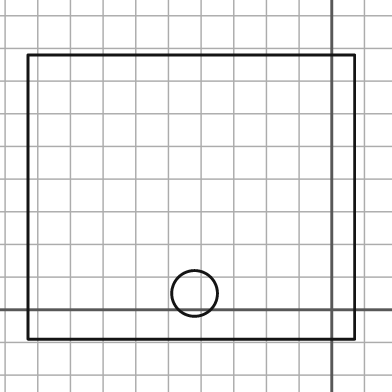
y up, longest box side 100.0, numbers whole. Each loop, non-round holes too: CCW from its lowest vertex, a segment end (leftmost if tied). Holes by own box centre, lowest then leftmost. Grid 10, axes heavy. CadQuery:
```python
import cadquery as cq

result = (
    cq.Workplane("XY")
    .moveTo(-93.0, -9.0)
    .lineTo(7.0, -9.0)
    .lineTo(7.0, 78.0)
    .lineTo(-93.0, 78.0)
    .close()
    .moveTo(-42.0, 5.0)
    .circle(7.0)
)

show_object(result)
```